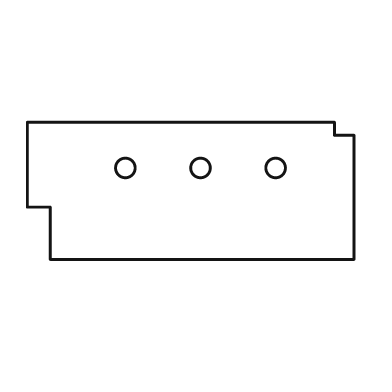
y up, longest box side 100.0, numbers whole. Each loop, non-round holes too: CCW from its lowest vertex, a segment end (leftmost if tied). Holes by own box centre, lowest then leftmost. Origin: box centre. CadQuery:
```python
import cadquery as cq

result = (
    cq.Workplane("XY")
    .moveTo(-43.0, -21.0)
    .lineTo(50.0, -21.0)
    .lineTo(50.0, 17.0)
    .lineTo(44.0, 17.0)
    .lineTo(44.0, 21.0)
    .lineTo(-50.0, 21.0)
    .lineTo(-50.0, -5.0)
    .lineTo(-43.0, -5.0)
    .close()
    .moveTo(-20.0, 7.0)
    .circle(3.0)
    .moveTo(3.0, 7.0)
    .circle(3.0)
    .moveTo(26.0, 7.0)
    .circle(3.0)
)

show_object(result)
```